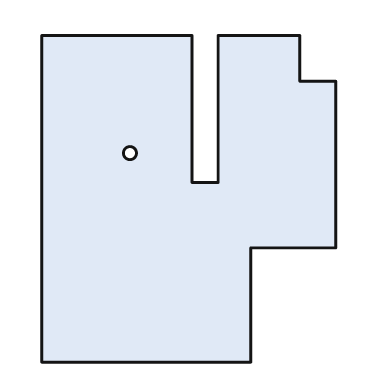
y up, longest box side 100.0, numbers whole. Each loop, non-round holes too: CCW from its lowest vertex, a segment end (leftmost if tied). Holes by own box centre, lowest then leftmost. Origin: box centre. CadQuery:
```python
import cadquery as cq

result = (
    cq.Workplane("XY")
    .moveTo(-45.0, -50.0)
    .lineTo(19.0, -50.0)
    .lineTo(19.0, -15.0)
    .lineTo(45.0, -15.0)
    .lineTo(45.0, 36.0)
    .lineTo(34.0, 36.0)
    .lineTo(34.0, 50.0)
    .lineTo(9.0, 50.0)
    .lineTo(9.0, 5.0)
    .lineTo(1.0, 5.0)
    .lineTo(1.0, 50.0)
    .lineTo(-45.0, 50.0)
    .close()
    .moveTo(-18.0, 14.0)
    .circle(2.0)
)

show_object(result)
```